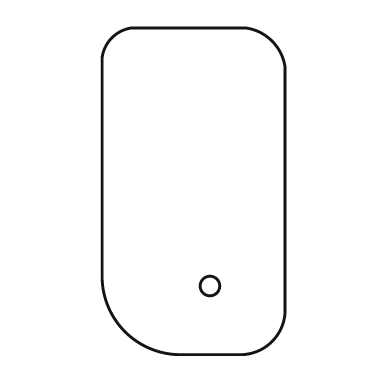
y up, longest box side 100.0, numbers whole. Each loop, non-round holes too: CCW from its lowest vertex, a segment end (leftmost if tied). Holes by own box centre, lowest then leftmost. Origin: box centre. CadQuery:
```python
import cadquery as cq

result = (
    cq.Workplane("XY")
    .moveTo(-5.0, -50.0)
    .lineTo(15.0, -50.0)
    .threePointArc((24.0, -46.0), (28.0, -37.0))
    .lineTo(28.0, 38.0)
    .threePointArc((24.0, 46.0), (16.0, 50.0))
    .lineTo(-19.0, 50.0)
    .threePointArc((-25.0, 47.0), (-28.0, 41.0))
    .lineTo(-28.0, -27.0)
    .threePointArc((-21.0, -43.0), (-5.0, -50.0))
    .close()
    .moveTo(5.0, -29.0)
    .circle(3.0)
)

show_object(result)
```